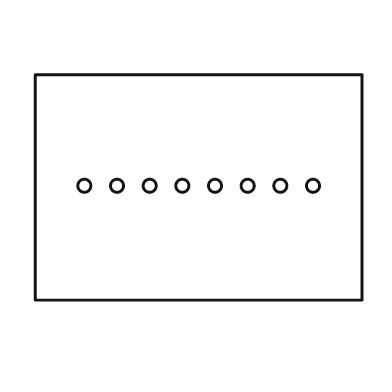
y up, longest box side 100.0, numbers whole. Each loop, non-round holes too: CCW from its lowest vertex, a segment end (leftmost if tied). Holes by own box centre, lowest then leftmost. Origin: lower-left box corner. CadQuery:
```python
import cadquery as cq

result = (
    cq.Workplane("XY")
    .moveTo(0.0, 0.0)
    .lineTo(100.0, 0.0)
    .lineTo(100.0, 69.0)
    .lineTo(0.0, 69.0)
    .close()
    .moveTo(15.0, 35.0)
    .circle(2.0)
    .moveTo(25.0, 35.0)
    .circle(2.0)
    .moveTo(35.0, 35.0)
    .circle(2.0)
    .moveTo(45.0, 35.0)
    .circle(2.0)
    .moveTo(55.0, 35.0)
    .circle(2.0)
    .moveTo(65.0, 35.0)
    .circle(2.0)
    .moveTo(75.0, 35.0)
    .circle(2.0)
    .moveTo(85.0, 35.0)
    .circle(2.0)
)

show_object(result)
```